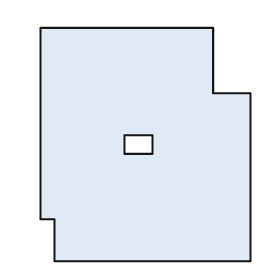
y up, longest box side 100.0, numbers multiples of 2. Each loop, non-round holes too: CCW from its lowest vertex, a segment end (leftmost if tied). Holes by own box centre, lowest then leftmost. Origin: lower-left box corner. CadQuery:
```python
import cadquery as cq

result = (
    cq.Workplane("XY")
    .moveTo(6.0, 0.0)
    .lineTo(90.0, 0.0)
    .lineTo(90.0, 72.0)
    .lineTo(74.0, 72.0)
    .lineTo(74.0, 100.0)
    .lineTo(0.0, 100.0)
    .lineTo(0.0, 18.0)
    .lineTo(6.0, 18.0)
    .close()
    .moveTo(36.0, 46.0)
    .lineTo(48.0, 46.0)
    .lineTo(48.0, 54.0)
    .lineTo(36.0, 54.0)
    .close()
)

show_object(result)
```